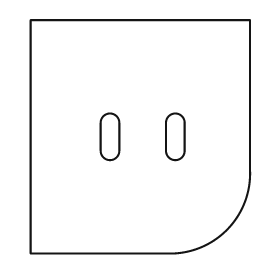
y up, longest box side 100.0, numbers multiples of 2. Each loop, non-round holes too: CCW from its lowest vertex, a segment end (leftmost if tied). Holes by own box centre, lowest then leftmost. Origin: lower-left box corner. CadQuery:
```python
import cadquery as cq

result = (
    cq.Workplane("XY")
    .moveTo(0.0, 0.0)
    .lineTo(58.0, 0.0)
    .threePointArc((84.0, 10.0), (94.0, 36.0))
    .lineTo(94.0, 100.0)
    .lineTo(0.0, 100.0)
    .close()
    .moveTo(30.0, 44.0)
    .threePointArc((34.0, 40.0), (38.0, 44.0))
    .lineTo(38.0, 56.0)
    .threePointArc((34.0, 60.0), (30.0, 56.0))
    .close()
    .moveTo(58.0, 44.0)
    .threePointArc((62.0, 40.0), (66.0, 44.0))
    .lineTo(66.0, 56.0)
    .threePointArc((62.0, 60.0), (58.0, 56.0))
    .close()
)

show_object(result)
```